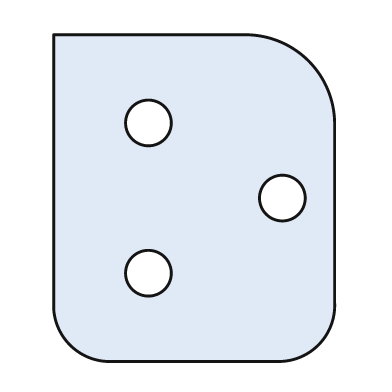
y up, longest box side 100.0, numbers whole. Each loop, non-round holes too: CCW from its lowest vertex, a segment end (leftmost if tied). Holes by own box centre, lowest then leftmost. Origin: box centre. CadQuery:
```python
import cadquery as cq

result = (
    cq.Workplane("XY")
    .moveTo(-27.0, -50.0)
    .lineTo(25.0, -50.0)
    .threePointArc((38.0, -45.0), (43.0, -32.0))
    .lineTo(43.0, 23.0)
    .threePointArc((35.0, 42.0), (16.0, 50.0))
    .lineTo(-43.0, 50.0)
    .lineTo(-43.0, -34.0)
    .threePointArc((-38.0, -45.0), (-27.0, -50.0))
    .close()
    .moveTo(-14.0, -23.0)
    .circle(7.0)
    .moveTo(27.0, 0.0)
    .circle(7.0)
    .moveTo(-14.0, 23.0)
    .circle(7.0)
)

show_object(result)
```